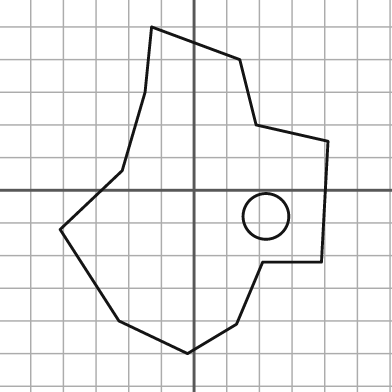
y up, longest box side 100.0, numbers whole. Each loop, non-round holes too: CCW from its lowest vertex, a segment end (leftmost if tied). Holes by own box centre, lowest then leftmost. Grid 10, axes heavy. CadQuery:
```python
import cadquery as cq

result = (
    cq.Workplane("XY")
    .moveTo(-2.0, -50.0)
    .lineTo(13.0, -41.0)
    .lineTo(21.0, -22.0)
    .lineTo(39.0, -22.0)
    .lineTo(41.0, 15.0)
    .lineTo(19.0, 20.0)
    .lineTo(14.0, 40.0)
    .lineTo(-13.0, 50.0)
    .lineTo(-15.0, 30.0)
    .lineTo(-22.0, 6.0)
    .lineTo(-41.0, -12.0)
    .lineTo(-23.0, -40.0)
    .close()
    .moveTo(22.0, -8.0)
    .circle(7.0)
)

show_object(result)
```